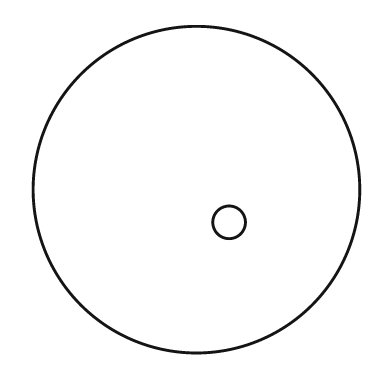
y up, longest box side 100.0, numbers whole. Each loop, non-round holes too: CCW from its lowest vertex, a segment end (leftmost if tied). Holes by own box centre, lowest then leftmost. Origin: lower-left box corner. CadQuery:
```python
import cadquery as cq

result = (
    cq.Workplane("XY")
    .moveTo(50.0, 50.0)
    .circle(50.0)
    .moveTo(60.0, 40.0)
    .circle(5.0)
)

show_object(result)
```